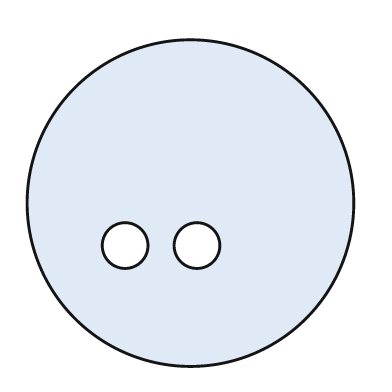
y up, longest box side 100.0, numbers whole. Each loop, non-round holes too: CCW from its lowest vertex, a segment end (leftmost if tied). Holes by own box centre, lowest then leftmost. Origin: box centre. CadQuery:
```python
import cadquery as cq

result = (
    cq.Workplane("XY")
    .moveTo(0.0, 0.0)
    .circle(50.0)
    .moveTo(-20.0, -13.0)
    .circle(7.0)
    .moveTo(2.0, -13.0)
    .circle(7.0)
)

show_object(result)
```